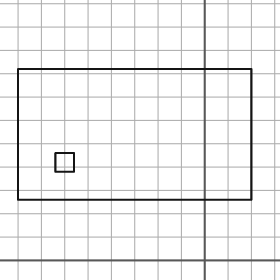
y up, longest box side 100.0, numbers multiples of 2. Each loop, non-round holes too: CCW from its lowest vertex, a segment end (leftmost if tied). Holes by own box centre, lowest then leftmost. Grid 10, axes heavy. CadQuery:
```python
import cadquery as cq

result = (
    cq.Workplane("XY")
    .moveTo(-80.0, 26.0)
    .lineTo(20.0, 26.0)
    .lineTo(20.0, 82.0)
    .lineTo(-80.0, 82.0)
    .close()
    .moveTo(-64.0, 38.0)
    .lineTo(-56.0, 38.0)
    .lineTo(-56.0, 46.0)
    .lineTo(-64.0, 46.0)
    .close()
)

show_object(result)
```